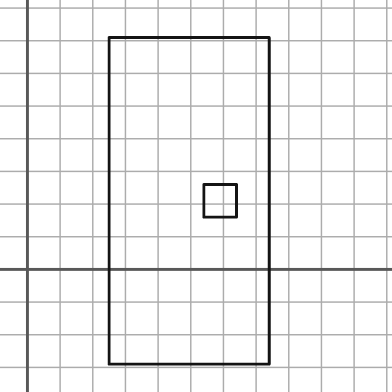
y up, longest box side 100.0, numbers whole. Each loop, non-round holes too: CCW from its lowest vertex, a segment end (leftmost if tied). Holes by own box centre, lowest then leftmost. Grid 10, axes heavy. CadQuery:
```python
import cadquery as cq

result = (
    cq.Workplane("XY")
    .moveTo(25.0, -29.0)
    .lineTo(74.0, -29.0)
    .lineTo(74.0, 71.0)
    .lineTo(25.0, 71.0)
    .close()
    .moveTo(54.0, 16.0)
    .lineTo(64.0, 16.0)
    .lineTo(64.0, 26.0)
    .lineTo(54.0, 26.0)
    .close()
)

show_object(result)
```